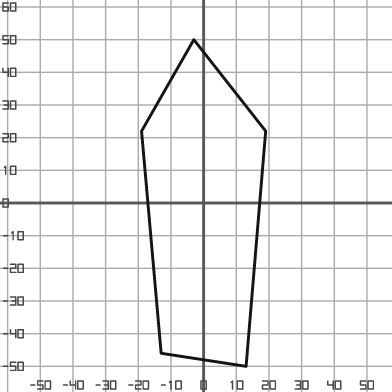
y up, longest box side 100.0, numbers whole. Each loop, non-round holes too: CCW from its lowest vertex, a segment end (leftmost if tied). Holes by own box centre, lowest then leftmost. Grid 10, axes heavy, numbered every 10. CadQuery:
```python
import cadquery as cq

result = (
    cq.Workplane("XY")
    .moveTo(13.0, -50.0)
    .lineTo(19.0, 22.0)
    .lineTo(-3.0, 50.0)
    .lineTo(-19.0, 22.0)
    .lineTo(-13.0, -46.0)
    .close()
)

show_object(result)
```